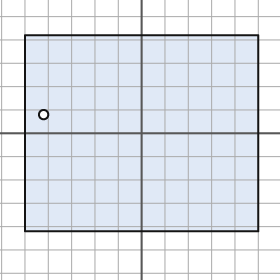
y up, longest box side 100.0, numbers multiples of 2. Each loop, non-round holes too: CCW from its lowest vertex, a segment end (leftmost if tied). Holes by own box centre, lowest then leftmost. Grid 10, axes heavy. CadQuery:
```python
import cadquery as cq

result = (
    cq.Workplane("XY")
    .moveTo(-50.0, -42.0)
    .lineTo(50.0, -42.0)
    .lineTo(50.0, 42.0)
    .lineTo(-50.0, 42.0)
    .close()
    .moveTo(-42.0, 8.0)
    .circle(2.0)
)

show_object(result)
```